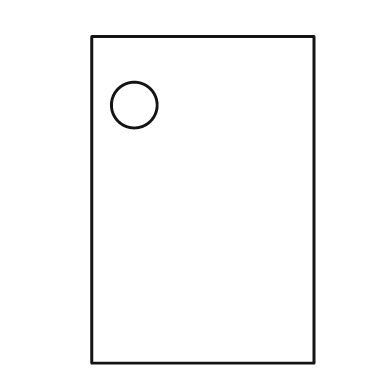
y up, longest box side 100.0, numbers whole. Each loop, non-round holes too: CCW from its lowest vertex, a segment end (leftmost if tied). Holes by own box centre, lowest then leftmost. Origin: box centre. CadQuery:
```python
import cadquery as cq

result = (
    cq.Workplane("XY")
    .moveTo(-34.0, -50.0)
    .lineTo(34.0, -50.0)
    .lineTo(34.0, 50.0)
    .lineTo(-34.0, 50.0)
    .close()
    .moveTo(-21.0, 29.0)
    .circle(7.0)
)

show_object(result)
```